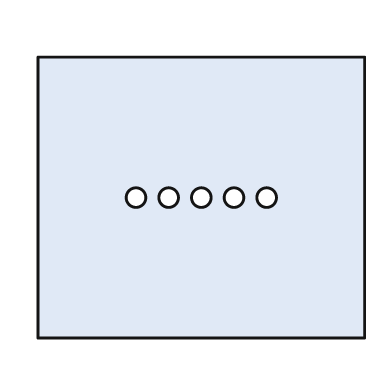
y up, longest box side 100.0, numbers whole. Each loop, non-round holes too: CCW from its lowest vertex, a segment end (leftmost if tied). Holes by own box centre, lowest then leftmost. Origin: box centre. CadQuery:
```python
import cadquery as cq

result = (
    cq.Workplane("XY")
    .moveTo(-50.0, -43.0)
    .lineTo(50.0, -43.0)
    .lineTo(50.0, 43.0)
    .lineTo(-50.0, 43.0)
    .close()
    .moveTo(-20.0, 0.0)
    .circle(3.0)
    .moveTo(-10.0, 0.0)
    .circle(3.0)
    .moveTo(0.0, 0.0)
    .circle(3.0)
    .moveTo(10.0, 0.0)
    .circle(3.0)
    .moveTo(20.0, 0.0)
    .circle(3.0)
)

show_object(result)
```